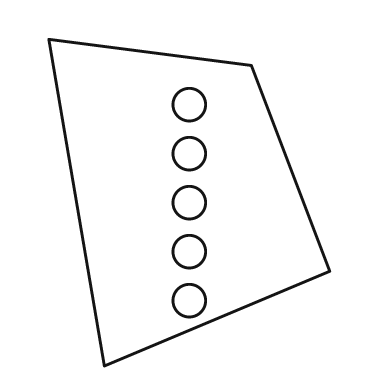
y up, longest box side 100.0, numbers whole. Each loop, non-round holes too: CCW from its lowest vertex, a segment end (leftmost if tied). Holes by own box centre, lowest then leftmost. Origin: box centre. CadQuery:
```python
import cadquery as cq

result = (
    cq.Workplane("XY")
    .moveTo(-26.0, -50.0)
    .lineTo(43.0, -21.0)
    .lineTo(19.0, 42.0)
    .lineTo(-43.0, 50.0)
    .close()
    .moveTo(0.0, -30.0)
    .circle(5.0)
    .moveTo(0.0, -15.0)
    .circle(5.0)
    .moveTo(0.0, 0.0)
    .circle(5.0)
    .moveTo(0.0, 15.0)
    .circle(5.0)
    .moveTo(0.0, 30.0)
    .circle(5.0)
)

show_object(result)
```